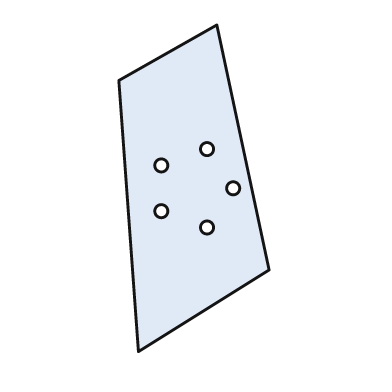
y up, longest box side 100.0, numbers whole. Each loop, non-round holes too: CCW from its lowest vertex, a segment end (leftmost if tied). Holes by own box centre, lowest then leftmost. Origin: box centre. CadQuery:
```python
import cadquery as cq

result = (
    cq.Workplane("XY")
    .moveTo(-17.0, -50.0)
    .lineTo(23.0, -25.0)
    .lineTo(7.0, 50.0)
    .lineTo(-23.0, 33.0)
    .close()
    .moveTo(4.0, -12.0)
    .circle(2.0)
    .moveTo(-10.0, -7.0)
    .circle(2.0)
    .moveTo(12.0, 0.0)
    .circle(2.0)
    .moveTo(-10.0, 7.0)
    .circle(2.0)
    .moveTo(4.0, 12.0)
    .circle(2.0)
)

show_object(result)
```